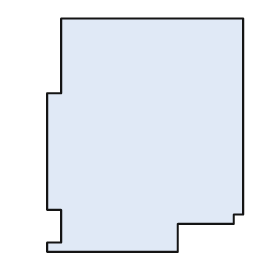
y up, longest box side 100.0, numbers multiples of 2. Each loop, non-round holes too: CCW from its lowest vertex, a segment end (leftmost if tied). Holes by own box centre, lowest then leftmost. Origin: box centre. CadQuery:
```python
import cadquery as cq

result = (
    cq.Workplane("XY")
    .moveTo(-42.0, -50.0)
    .lineTo(14.0, -50.0)
    .lineTo(14.0, -38.0)
    .lineTo(38.0, -38.0)
    .lineTo(38.0, -34.0)
    .lineTo(42.0, -34.0)
    .lineTo(42.0, 50.0)
    .lineTo(-36.0, 50.0)
    .lineTo(-36.0, 18.0)
    .lineTo(-42.0, 18.0)
    .lineTo(-42.0, -32.0)
    .lineTo(-36.0, -32.0)
    .lineTo(-36.0, -46.0)
    .lineTo(-42.0, -46.0)
    .close()
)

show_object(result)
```